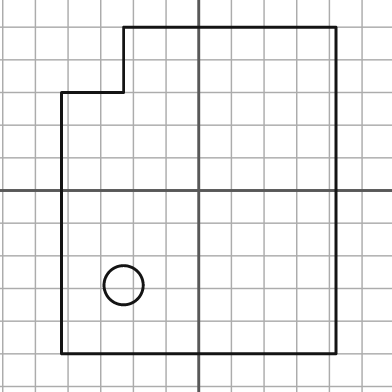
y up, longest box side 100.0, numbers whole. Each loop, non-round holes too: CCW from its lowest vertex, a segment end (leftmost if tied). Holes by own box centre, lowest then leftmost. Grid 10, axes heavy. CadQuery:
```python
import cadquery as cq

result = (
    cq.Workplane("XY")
    .moveTo(-42.0, -50.0)
    .lineTo(42.0, -50.0)
    .lineTo(42.0, 50.0)
    .lineTo(-23.0, 50.0)
    .lineTo(-23.0, 30.0)
    .lineTo(-42.0, 30.0)
    .close()
    .moveTo(-23.0, -29.0)
    .circle(6.0)
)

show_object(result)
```